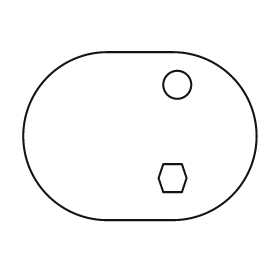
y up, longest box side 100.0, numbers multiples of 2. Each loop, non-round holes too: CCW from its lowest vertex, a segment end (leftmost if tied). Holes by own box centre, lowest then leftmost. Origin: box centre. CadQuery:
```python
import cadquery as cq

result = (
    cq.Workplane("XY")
    .moveTo(-14.0, -36.0)
    .lineTo(14.0, -36.0)
    .threePointArc((50.0, 0.0), (14.0, 36.0))
    .lineTo(-14.0, 36.0)
    .threePointArc((-50.0, 0.0), (-14.0, -36.0))
    .close()
    .moveTo(10.0, -24.0)
    .lineTo(18.0, -24.0)
    .lineTo(20.0, -18.0)
    .lineTo(18.0, -12.0)
    .lineTo(10.0, -12.0)
    .lineTo(8.0, -18.0)
    .close()
    .moveTo(16.0, 22.0)
    .circle(6.0)
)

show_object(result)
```